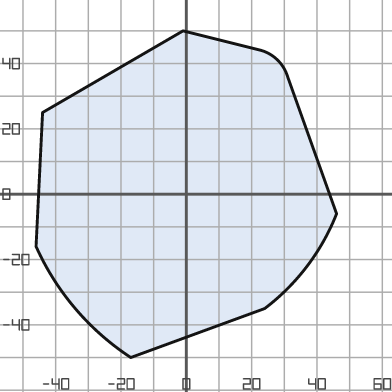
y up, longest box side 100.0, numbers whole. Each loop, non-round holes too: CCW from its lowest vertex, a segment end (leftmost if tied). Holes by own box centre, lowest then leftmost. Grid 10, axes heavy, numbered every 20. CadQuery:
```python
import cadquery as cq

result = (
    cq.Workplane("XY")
    .moveTo(-17.0, -50.0)
    .lineTo(24.0, -35.0)
    .threePointArc((37.0, -22.0), (46.0, -6.0))
    .lineTo(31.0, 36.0)
    .threePointArc((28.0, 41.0), (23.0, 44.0))
    .lineTo(-1.0, 50.0)
    .lineTo(-44.0, 25.0)
    .lineTo(-46.0, -16.0)
    .threePointArc((-34.0, -35.0), (-17.0, -50.0))
    .close()
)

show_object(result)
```